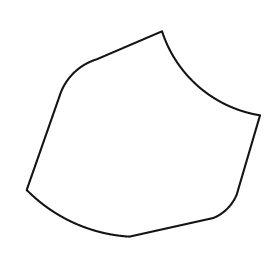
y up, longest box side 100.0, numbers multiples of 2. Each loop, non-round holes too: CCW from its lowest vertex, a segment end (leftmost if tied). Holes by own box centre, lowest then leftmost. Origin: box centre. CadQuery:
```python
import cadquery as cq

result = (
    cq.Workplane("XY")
    .moveTo(-6.0, -44.0)
    .lineTo(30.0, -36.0)
    .threePointArc((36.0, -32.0), (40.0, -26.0))
    .lineTo(50.0, 8.0)
    .threePointArc((24.0, 20.0), (8.0, 44.0))
    .lineTo(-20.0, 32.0)
    .threePointArc((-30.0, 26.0), (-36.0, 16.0))
    .lineTo(-50.0, -24.0)
    .threePointArc((-30.0, -38.0), (-6.0, -44.0))
    .close()
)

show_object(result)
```